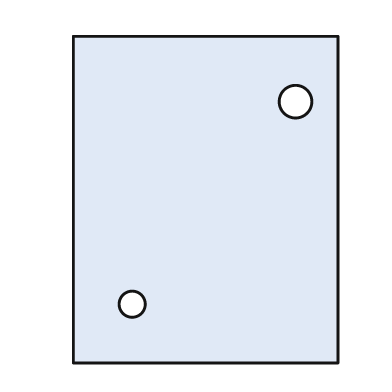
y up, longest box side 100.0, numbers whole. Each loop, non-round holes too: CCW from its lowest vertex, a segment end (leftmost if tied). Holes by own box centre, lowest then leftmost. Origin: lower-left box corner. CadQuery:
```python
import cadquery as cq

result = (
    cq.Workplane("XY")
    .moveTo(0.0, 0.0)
    .lineTo(81.0, 0.0)
    .lineTo(81.0, 100.0)
    .lineTo(0.0, 100.0)
    .close()
    .moveTo(18.0, 18.0)
    .circle(4.0)
    .moveTo(68.0, 80.0)
    .circle(5.0)
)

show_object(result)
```